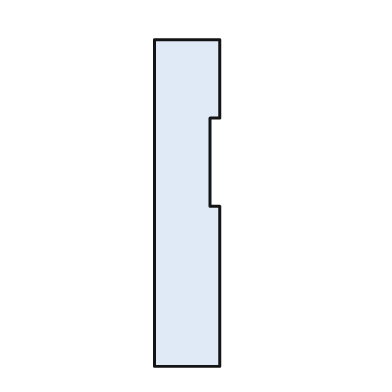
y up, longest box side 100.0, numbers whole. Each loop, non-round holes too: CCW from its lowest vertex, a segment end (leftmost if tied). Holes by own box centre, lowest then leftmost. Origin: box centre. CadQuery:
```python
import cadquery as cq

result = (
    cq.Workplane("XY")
    .moveTo(-10.0, -50.0)
    .lineTo(10.0, -50.0)
    .lineTo(10.0, -1.0)
    .lineTo(7.0, -1.0)
    .lineTo(7.0, 26.0)
    .lineTo(10.0, 26.0)
    .lineTo(10.0, 50.0)
    .lineTo(-10.0, 50.0)
    .close()
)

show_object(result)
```